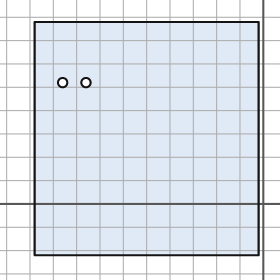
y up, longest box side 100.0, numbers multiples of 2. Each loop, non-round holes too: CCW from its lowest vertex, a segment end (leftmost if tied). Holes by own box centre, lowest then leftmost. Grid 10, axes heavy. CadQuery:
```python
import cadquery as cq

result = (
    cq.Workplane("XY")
    .moveTo(-98.0, -22.0)
    .lineTo(-2.0, -22.0)
    .lineTo(-2.0, 78.0)
    .lineTo(-98.0, 78.0)
    .close()
    .moveTo(-86.0, 52.0)
    .circle(2.0)
    .moveTo(-76.0, 52.0)
    .circle(2.0)
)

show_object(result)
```